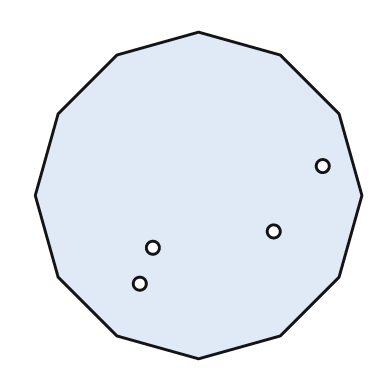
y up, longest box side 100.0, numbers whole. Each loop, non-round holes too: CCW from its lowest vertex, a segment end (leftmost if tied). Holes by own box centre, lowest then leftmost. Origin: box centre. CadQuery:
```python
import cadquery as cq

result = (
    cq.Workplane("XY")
    .moveTo(0.0, -50.0)
    .lineTo(25.0, -43.0)
    .lineTo(43.0, -25.0)
    .lineTo(50.0, 0.0)
    .lineTo(43.0, 25.0)
    .lineTo(25.0, 43.0)
    .lineTo(0.0, 50.0)
    .lineTo(-25.0, 43.0)
    .lineTo(-43.0, 25.0)
    .lineTo(-50.0, 0.0)
    .lineTo(-43.0, -25.0)
    .lineTo(-25.0, -43.0)
    .close()
    .moveTo(-18.0, -27.0)
    .circle(2.0)
    .moveTo(-14.0, -16.0)
    .circle(2.0)
    .moveTo(23.0, -11.0)
    .circle(2.0)
    .moveTo(38.0, 9.0)
    .circle(2.0)
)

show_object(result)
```